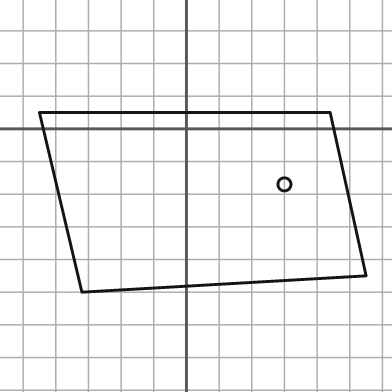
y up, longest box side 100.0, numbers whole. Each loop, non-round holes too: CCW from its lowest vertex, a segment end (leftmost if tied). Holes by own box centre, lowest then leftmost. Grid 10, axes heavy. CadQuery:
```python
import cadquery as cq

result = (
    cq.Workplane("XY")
    .moveTo(-32.0, -50.0)
    .lineTo(55.0, -45.0)
    .lineTo(44.0, 5.0)
    .lineTo(-45.0, 5.0)
    .close()
    .moveTo(30.0, -17.0)
    .circle(2.0)
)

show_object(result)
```